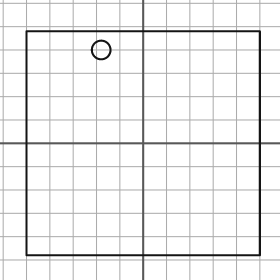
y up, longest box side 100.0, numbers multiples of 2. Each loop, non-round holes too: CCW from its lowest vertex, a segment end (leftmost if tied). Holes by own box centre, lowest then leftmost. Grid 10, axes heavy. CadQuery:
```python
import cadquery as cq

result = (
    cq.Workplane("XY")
    .moveTo(-50.0, -48.0)
    .lineTo(50.0, -48.0)
    .lineTo(50.0, 48.0)
    .lineTo(-50.0, 48.0)
    .close()
    .moveTo(-18.0, 40.0)
    .circle(4.0)
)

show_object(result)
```